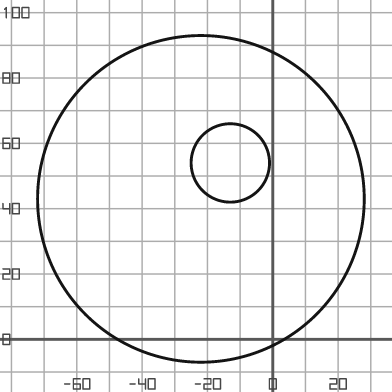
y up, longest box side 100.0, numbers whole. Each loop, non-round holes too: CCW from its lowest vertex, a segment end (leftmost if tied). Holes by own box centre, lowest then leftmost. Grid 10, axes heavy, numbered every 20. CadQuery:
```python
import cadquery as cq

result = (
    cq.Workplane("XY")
    .moveTo(-22.0, 43.0)
    .circle(50.0)
    .moveTo(-13.0, 54.0)
    .circle(12.0)
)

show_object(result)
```